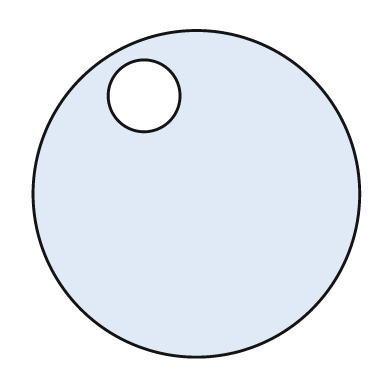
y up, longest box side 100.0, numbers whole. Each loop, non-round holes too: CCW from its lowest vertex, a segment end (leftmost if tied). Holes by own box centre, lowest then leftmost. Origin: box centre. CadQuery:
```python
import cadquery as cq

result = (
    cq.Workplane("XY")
    .moveTo(0.0, 0.0)
    .circle(50.0)
    .moveTo(-16.0, 30.0)
    .circle(11.0)
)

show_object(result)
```